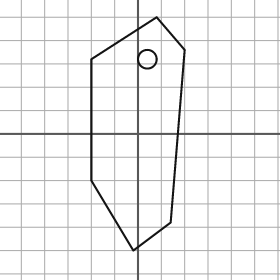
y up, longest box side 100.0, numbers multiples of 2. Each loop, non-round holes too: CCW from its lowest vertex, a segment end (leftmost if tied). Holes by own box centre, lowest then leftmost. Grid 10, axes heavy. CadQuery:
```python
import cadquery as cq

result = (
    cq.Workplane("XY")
    .moveTo(-2.0, -50.0)
    .lineTo(14.0, -38.0)
    .lineTo(20.0, 36.0)
    .lineTo(8.0, 50.0)
    .lineTo(-20.0, 32.0)
    .lineTo(-20.0, -20.0)
    .close()
    .moveTo(4.0, 32.0)
    .circle(4.0)
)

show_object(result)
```